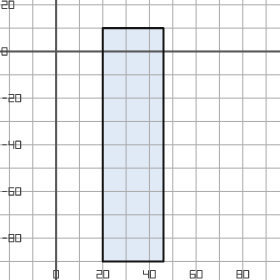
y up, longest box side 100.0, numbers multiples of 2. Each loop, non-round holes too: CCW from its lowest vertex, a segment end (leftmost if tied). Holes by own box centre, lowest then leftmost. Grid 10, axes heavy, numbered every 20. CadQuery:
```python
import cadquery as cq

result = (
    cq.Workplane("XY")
    .moveTo(20.0, -90.0)
    .lineTo(46.0, -90.0)
    .lineTo(46.0, 10.0)
    .lineTo(20.0, 10.0)
    .close()
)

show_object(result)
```